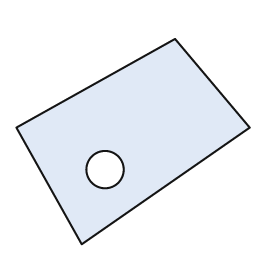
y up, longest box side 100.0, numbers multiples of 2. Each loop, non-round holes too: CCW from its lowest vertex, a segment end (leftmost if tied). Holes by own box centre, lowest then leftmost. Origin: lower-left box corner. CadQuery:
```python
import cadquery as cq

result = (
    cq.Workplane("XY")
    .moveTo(28.0, 0.0)
    .lineTo(100.0, 50.0)
    .lineTo(68.0, 88.0)
    .lineTo(0.0, 50.0)
    .close()
    .moveTo(38.0, 32.0)
    .circle(8.0)
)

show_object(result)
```